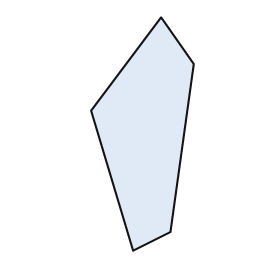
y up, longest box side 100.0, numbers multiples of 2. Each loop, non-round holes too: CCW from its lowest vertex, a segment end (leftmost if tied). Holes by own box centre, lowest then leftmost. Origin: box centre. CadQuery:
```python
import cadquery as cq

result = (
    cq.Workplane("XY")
    .moveTo(-4.0, -50.0)
    .lineTo(12.0, -42.0)
    .lineTo(22.0, 30.0)
    .lineTo(8.0, 50.0)
    .lineTo(-22.0, 10.0)
    .close()
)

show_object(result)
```